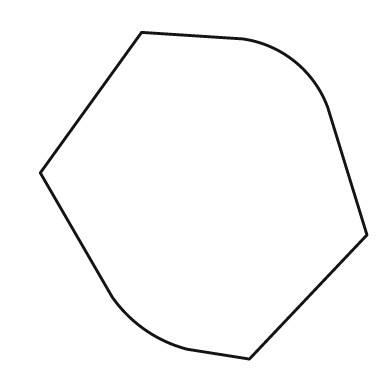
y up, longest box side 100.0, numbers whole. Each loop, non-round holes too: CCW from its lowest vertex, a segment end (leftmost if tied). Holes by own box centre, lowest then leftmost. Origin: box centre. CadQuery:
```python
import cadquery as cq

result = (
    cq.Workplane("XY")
    .moveTo(14.0, -50.0)
    .lineTo(50.0, -12.0)
    .lineTo(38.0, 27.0)
    .threePointArc((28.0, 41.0), (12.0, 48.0))
    .lineTo(-19.0, 50.0)
    .lineTo(-50.0, 7.0)
    .lineTo(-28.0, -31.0)
    .threePointArc((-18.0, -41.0), (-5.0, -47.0))
    .close()
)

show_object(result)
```